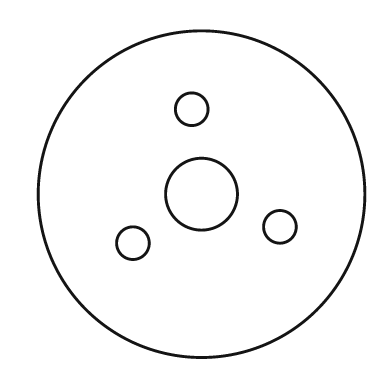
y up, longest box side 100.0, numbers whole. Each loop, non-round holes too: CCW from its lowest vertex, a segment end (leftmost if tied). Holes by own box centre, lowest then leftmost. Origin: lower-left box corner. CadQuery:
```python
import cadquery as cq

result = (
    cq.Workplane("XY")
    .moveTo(50.0, 50.0)
    .circle(50.0)
    .moveTo(29.0, 35.0)
    .circle(5.0)
    .moveTo(74.0, 40.0)
    .circle(5.0)
    .moveTo(50.0, 50.0)
    .circle(11.0)
    .moveTo(47.0, 76.0)
    .circle(5.0)
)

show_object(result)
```